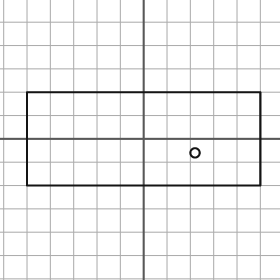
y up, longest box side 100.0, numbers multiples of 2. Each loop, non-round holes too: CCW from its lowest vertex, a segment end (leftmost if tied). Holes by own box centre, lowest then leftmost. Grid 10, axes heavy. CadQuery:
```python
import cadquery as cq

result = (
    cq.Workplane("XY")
    .moveTo(-50.0, -20.0)
    .lineTo(50.0, -20.0)
    .lineTo(50.0, 20.0)
    .lineTo(-50.0, 20.0)
    .close()
    .moveTo(22.0, -6.0)
    .circle(2.0)
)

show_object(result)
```